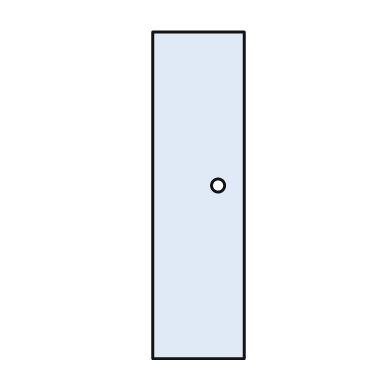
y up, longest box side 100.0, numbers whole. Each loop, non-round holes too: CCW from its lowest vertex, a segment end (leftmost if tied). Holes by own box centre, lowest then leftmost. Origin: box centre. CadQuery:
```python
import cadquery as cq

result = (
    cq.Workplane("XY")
    .moveTo(-14.0, -50.0)
    .lineTo(14.0, -50.0)
    .lineTo(14.0, 50.0)
    .lineTo(-14.0, 50.0)
    .close()
    .moveTo(6.0, 3.0)
    .circle(2.0)
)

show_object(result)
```